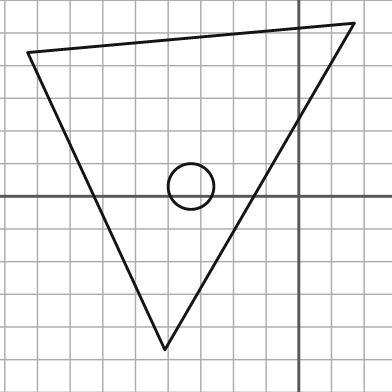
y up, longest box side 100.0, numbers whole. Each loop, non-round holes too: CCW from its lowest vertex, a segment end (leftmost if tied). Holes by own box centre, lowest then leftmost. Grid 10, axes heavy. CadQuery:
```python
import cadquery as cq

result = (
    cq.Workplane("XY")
    .moveTo(-41.0, -47.0)
    .lineTo(17.0, 53.0)
    .lineTo(-83.0, 44.0)
    .close()
    .moveTo(-33.0, 3.0)
    .circle(7.0)
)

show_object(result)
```